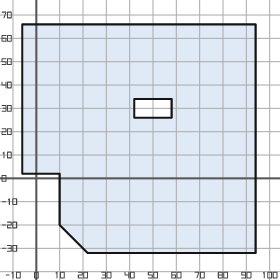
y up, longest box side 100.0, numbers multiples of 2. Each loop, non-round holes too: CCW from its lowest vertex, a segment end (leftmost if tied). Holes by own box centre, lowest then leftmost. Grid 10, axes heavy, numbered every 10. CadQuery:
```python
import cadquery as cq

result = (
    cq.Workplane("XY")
    .moveTo(22.0, -32.0)
    .lineTo(94.0, -32.0)
    .lineTo(94.0, 66.0)
    .lineTo(-6.0, 66.0)
    .lineTo(-6.0, 2.0)
    .lineTo(10.0, 2.0)
    .lineTo(10.0, -20.0)
    .close()
    .moveTo(42.0, 26.0)
    .lineTo(58.0, 26.0)
    .lineTo(58.0, 34.0)
    .lineTo(42.0, 34.0)
    .close()
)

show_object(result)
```